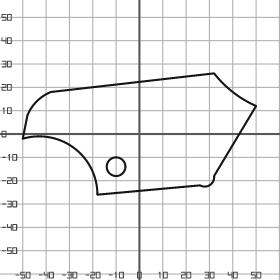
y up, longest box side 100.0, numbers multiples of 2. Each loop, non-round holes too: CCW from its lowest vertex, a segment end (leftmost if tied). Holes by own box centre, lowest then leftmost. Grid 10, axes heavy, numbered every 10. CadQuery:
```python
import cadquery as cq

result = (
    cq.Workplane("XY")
    .moveTo(-18.0, -26.0)
    .lineTo(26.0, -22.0)
    .threePointArc((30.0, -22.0), (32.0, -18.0))
    .lineTo(50.0, 12.0)
    .threePointArc((40.0, 18.0), (32.0, 26.0))
    .lineTo(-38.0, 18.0)
    .threePointArc((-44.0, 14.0), (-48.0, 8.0))
    .lineTo(-50.0, -2.0)
    .threePointArc((-28.0, -6.0), (-18.0, -26.0))
    .close()
    .moveTo(-10.0, -14.0)
    .circle(4.0)
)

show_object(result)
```